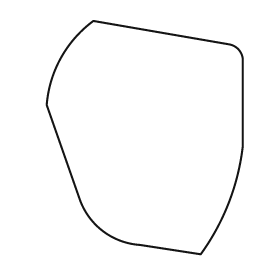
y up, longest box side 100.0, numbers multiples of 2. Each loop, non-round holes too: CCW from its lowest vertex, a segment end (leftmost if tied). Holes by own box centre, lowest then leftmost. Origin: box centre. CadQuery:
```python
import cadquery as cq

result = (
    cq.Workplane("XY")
    .moveTo(24.0, -50.0)
    .threePointArc((36.0, -28.0), (42.0, -4.0))
    .lineTo(42.0, 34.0)
    .threePointArc((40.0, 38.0), (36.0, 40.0))
    .lineTo(-22.0, 50.0)
    .threePointArc((-36.0, 34.0), (-42.0, 14.0))
    .lineTo(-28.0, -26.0)
    .threePointArc((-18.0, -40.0), (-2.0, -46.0))
    .close()
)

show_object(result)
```